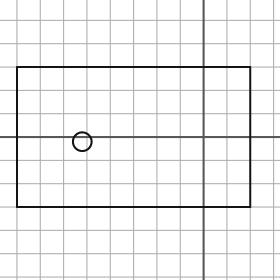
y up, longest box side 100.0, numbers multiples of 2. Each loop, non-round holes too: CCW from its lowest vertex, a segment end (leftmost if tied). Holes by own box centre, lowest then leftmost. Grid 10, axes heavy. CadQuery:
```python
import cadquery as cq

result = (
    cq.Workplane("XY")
    .moveTo(-80.0, -30.0)
    .lineTo(20.0, -30.0)
    .lineTo(20.0, 30.0)
    .lineTo(-80.0, 30.0)
    .close()
    .moveTo(-52.0, -2.0)
    .circle(4.0)
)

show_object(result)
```